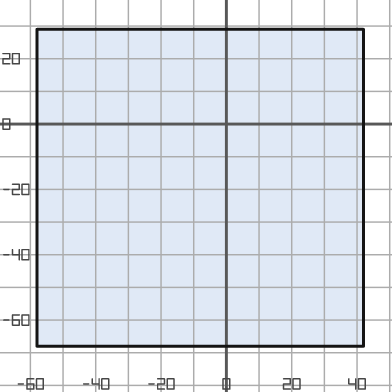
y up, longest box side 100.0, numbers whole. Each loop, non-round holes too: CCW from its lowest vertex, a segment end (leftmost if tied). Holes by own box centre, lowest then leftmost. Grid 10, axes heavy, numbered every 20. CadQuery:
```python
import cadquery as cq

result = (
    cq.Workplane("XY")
    .moveTo(-58.0, -68.0)
    .lineTo(42.0, -68.0)
    .lineTo(42.0, 29.0)
    .lineTo(-58.0, 29.0)
    .close()
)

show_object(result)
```